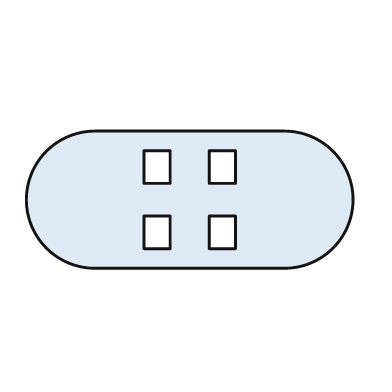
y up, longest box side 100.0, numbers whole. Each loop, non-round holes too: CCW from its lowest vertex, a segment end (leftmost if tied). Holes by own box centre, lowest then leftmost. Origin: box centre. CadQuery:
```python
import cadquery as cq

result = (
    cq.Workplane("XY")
    .moveTo(-29.0, -21.0)
    .lineTo(29.0, -21.0)
    .threePointArc((50.0, 0.0), (29.0, 21.0))
    .lineTo(-29.0, 21.0)
    .threePointArc((-50.0, 0.0), (-29.0, -21.0))
    .close()
    .moveTo(-14.0, -15.0)
    .lineTo(-6.0, -15.0)
    .lineTo(-6.0, -5.0)
    .lineTo(-14.0, -5.0)
    .close()
    .moveTo(6.0, -15.0)
    .lineTo(14.0, -15.0)
    .lineTo(14.0, -5.0)
    .lineTo(6.0, -5.0)
    .close()
    .moveTo(-14.0, 5.0)
    .lineTo(-6.0, 5.0)
    .lineTo(-6.0, 15.0)
    .lineTo(-14.0, 15.0)
    .close()
    .moveTo(6.0, 5.0)
    .lineTo(14.0, 5.0)
    .lineTo(14.0, 15.0)
    .lineTo(6.0, 15.0)
    .close()
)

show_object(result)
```